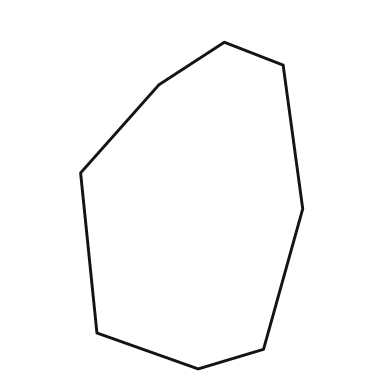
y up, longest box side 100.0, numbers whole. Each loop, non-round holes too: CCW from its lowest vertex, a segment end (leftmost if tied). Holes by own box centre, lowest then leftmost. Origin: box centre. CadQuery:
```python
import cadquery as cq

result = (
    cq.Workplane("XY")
    .moveTo(2.0, -50.0)
    .lineTo(22.0, -44.0)
    .lineTo(34.0, -1.0)
    .lineTo(28.0, 43.0)
    .lineTo(10.0, 50.0)
    .lineTo(-10.0, 37.0)
    .lineTo(-34.0, 10.0)
    .lineTo(-29.0, -39.0)
    .close()
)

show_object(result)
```